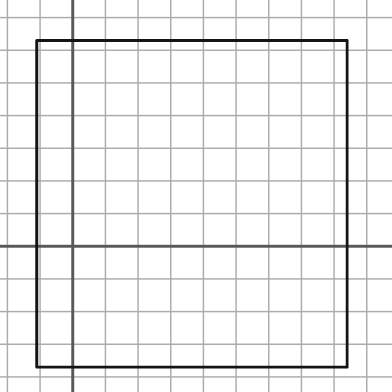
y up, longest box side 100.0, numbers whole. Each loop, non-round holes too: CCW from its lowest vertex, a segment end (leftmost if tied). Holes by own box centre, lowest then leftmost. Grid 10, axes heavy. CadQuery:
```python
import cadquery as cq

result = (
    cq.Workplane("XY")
    .moveTo(-11.0, -37.0)
    .lineTo(84.0, -37.0)
    .lineTo(84.0, 63.0)
    .lineTo(-11.0, 63.0)
    .close()
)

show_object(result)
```